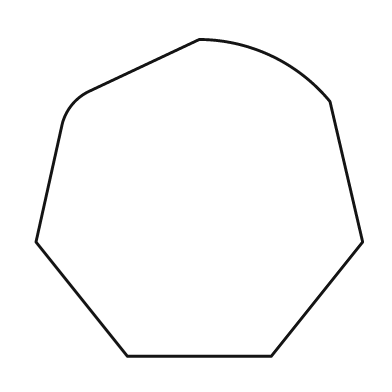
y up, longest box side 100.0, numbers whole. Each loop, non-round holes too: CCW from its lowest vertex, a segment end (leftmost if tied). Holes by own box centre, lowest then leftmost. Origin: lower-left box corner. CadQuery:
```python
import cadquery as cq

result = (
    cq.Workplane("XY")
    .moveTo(28.0, 0.0)
    .lineTo(72.0, 0.0)
    .lineTo(100.0, 35.0)
    .lineTo(90.0, 78.0)
    .threePointArc((72.0, 92.0), (50.0, 97.0))
    .lineTo(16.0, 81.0)
    .threePointArc((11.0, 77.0), (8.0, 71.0))
    .lineTo(0.0, 35.0)
    .close()
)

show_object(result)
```